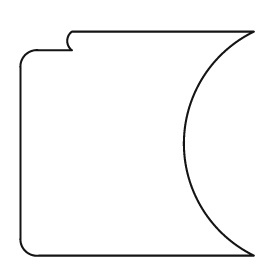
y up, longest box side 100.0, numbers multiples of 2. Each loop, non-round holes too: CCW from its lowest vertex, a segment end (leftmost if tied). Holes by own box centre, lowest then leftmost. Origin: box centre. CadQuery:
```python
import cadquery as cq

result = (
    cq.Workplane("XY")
    .moveTo(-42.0, -48.0)
    .lineTo(50.0, -48.0)
    .threePointArc((20.0, 0.0), (50.0, 48.0))
    .lineTo(-28.0, 48.0)
    .threePointArc((-30.0, 44.0), (-28.0, 40.0))
    .lineTo(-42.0, 40.0)
    .threePointArc((-48.0, 38.0), (-50.0, 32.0))
    .lineTo(-50.0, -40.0)
    .threePointArc((-48.0, -46.0), (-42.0, -48.0))
    .close()
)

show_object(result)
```